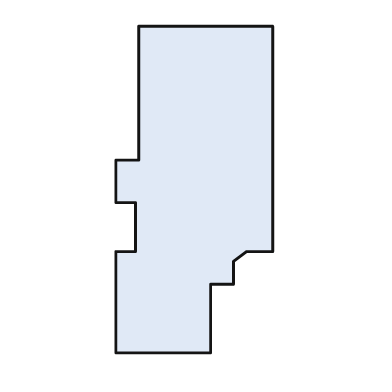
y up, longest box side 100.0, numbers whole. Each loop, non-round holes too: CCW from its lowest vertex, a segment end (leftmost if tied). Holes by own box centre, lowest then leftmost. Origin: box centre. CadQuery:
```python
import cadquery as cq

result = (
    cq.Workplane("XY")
    .moveTo(-24.0, -50.0)
    .lineTo(5.0, -50.0)
    .lineTo(5.0, -29.0)
    .lineTo(12.0, -29.0)
    .lineTo(12.0, -22.0)
    .lineTo(16.0, -19.0)
    .lineTo(24.0, -19.0)
    .lineTo(24.0, 50.0)
    .lineTo(-17.0, 50.0)
    .lineTo(-17.0, 9.0)
    .lineTo(-24.0, 9.0)
    .lineTo(-24.0, -4.0)
    .lineTo(-18.0, -4.0)
    .lineTo(-18.0, -19.0)
    .lineTo(-24.0, -19.0)
    .close()
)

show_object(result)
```